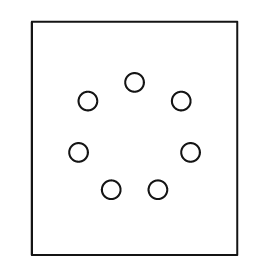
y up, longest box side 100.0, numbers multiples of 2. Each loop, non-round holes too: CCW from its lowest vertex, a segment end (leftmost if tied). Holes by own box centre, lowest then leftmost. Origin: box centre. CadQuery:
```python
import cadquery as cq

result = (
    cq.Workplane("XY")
    .moveTo(-44.0, -50.0)
    .lineTo(44.0, -50.0)
    .lineTo(44.0, 50.0)
    .lineTo(-44.0, 50.0)
    .close()
    .moveTo(-10.0, -22.0)
    .circle(4.0)
    .moveTo(10.0, -22.0)
    .circle(4.0)
    .moveTo(-24.0, -6.0)
    .circle(4.0)
    .moveTo(24.0, -6.0)
    .circle(4.0)
    .moveTo(-20.0, 16.0)
    .circle(4.0)
    .moveTo(20.0, 16.0)
    .circle(4.0)
    .moveTo(0.0, 24.0)
    .circle(4.0)
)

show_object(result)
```